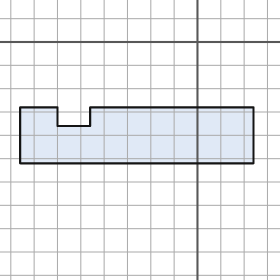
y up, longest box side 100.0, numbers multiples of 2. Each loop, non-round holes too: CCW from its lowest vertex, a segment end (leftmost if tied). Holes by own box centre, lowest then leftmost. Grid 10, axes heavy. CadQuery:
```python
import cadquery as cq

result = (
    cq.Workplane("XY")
    .moveTo(-76.0, -52.0)
    .lineTo(24.0, -52.0)
    .lineTo(24.0, -28.0)
    .lineTo(-46.0, -28.0)
    .lineTo(-46.0, -36.0)
    .lineTo(-60.0, -36.0)
    .lineTo(-60.0, -28.0)
    .lineTo(-76.0, -28.0)
    .close()
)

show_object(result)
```